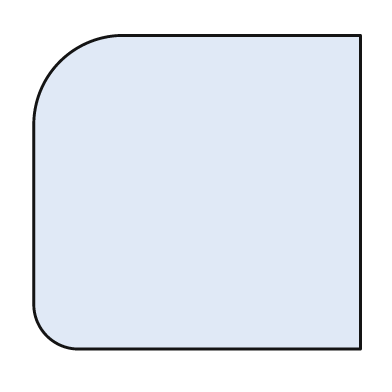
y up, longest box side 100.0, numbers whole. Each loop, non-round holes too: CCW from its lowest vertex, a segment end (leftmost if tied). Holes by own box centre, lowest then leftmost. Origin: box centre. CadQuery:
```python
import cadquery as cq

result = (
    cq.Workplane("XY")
    .moveTo(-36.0, -48.0)
    .lineTo(50.0, -48.0)
    .lineTo(50.0, 48.0)
    .lineTo(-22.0, 48.0)
    .threePointArc((-42.0, 40.0), (-50.0, 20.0))
    .lineTo(-50.0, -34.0)
    .threePointArc((-46.0, -44.0), (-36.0, -48.0))
    .close()
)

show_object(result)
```